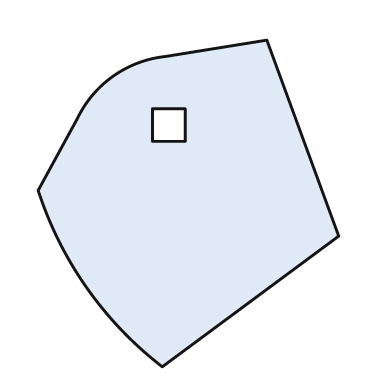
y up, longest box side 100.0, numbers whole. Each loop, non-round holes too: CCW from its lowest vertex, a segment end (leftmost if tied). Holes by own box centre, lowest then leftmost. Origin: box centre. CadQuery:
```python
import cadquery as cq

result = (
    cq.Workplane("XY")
    .moveTo(-8.0, -50.0)
    .lineTo(46.0, -10.0)
    .lineTo(24.0, 50.0)
    .lineTo(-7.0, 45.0)
    .threePointArc((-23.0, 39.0), (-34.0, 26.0))
    .lineTo(-46.0, 4.0)
    .threePointArc((-31.0, -26.0), (-8.0, -50.0))
    .close()
    .moveTo(-11.0, 19.0)
    .lineTo(-1.0, 19.0)
    .lineTo(-1.0, 29.0)
    .lineTo(-11.0, 29.0)
    .close()
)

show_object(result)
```